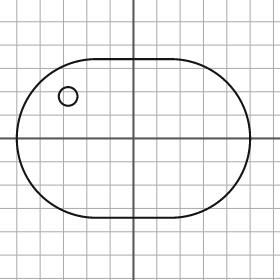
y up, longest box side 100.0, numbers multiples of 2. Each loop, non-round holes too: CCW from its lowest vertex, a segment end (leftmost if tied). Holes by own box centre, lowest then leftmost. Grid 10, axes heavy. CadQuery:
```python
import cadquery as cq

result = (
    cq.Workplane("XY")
    .moveTo(-16.0, -34.0)
    .lineTo(16.0, -34.0)
    .threePointArc((50.0, 0.0), (16.0, 34.0))
    .lineTo(-16.0, 34.0)
    .threePointArc((-50.0, 0.0), (-16.0, -34.0))
    .close()
    .moveTo(-28.0, 18.0)
    .circle(4.0)
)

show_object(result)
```